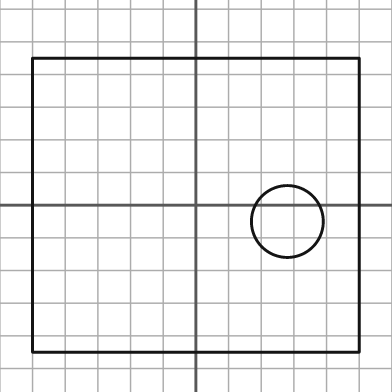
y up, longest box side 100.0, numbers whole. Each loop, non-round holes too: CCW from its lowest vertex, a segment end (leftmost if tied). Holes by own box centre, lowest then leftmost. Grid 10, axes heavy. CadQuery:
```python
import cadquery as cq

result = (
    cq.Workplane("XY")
    .moveTo(-50.0, -45.0)
    .lineTo(50.0, -45.0)
    .lineTo(50.0, 45.0)
    .lineTo(-50.0, 45.0)
    .close()
    .moveTo(28.0, -5.0)
    .circle(11.0)
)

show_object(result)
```